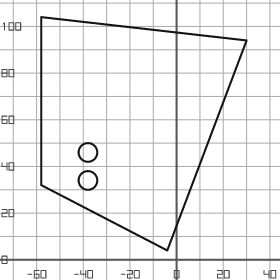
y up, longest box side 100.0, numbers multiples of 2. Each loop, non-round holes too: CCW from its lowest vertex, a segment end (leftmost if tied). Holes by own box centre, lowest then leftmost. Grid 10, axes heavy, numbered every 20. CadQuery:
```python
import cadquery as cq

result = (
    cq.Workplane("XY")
    .moveTo(-4.0, 4.0)
    .lineTo(30.0, 94.0)
    .lineTo(-58.0, 104.0)
    .lineTo(-58.0, 32.0)
    .close()
    .moveTo(-38.0, 34.0)
    .circle(4.0)
    .moveTo(-38.0, 46.0)
    .circle(4.0)
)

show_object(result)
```